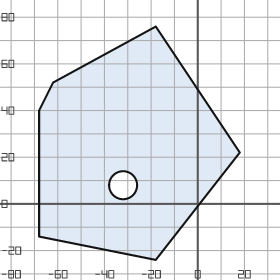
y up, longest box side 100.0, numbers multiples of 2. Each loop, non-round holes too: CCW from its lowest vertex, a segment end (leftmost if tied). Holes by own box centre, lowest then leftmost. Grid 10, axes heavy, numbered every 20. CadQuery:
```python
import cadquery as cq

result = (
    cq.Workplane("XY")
    .moveTo(-18.0, -24.0)
    .lineTo(18.0, 22.0)
    .lineTo(-18.0, 76.0)
    .lineTo(-62.0, 52.0)
    .lineTo(-68.0, 40.0)
    .lineTo(-68.0, -14.0)
    .close()
    .moveTo(-32.0, 8.0)
    .circle(6.0)
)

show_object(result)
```